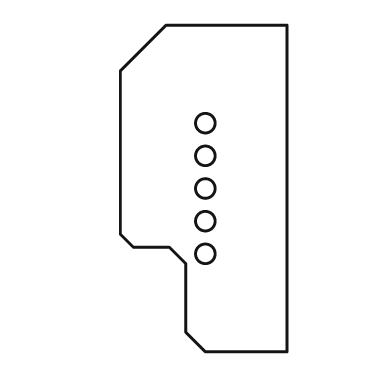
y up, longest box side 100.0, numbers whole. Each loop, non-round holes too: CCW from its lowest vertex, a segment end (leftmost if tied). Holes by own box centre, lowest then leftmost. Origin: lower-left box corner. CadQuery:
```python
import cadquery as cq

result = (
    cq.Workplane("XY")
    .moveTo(26.0, 0.0)
    .lineTo(51.0, 0.0)
    .lineTo(51.0, 100.0)
    .lineTo(14.0, 100.0)
    .lineTo(0.0, 86.0)
    .lineTo(0.0, 36.0)
    .lineTo(4.0, 32.0)
    .lineTo(15.0, 32.0)
    .lineTo(20.0, 27.0)
    .lineTo(20.0, 6.0)
    .close()
    .moveTo(26.0, 30.0)
    .circle(3.0)
    .moveTo(26.0, 40.0)
    .circle(3.0)
    .moveTo(26.0, 50.0)
    .circle(3.0)
    .moveTo(26.0, 60.0)
    .circle(3.0)
    .moveTo(26.0, 70.0)
    .circle(3.0)
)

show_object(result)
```